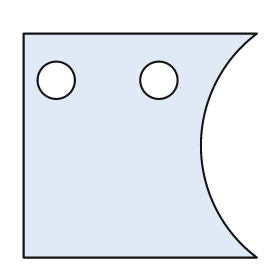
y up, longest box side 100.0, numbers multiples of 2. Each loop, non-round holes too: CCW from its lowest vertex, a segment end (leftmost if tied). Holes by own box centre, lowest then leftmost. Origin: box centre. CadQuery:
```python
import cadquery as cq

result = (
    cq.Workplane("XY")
    .moveTo(-50.0, -48.0)
    .lineTo(50.0, -48.0)
    .threePointArc((26.0, 0.0), (50.0, 48.0))
    .lineTo(-50.0, 48.0)
    .close()
    .moveTo(-36.0, 28.0)
    .circle(8.0)
    .moveTo(8.0, 28.0)
    .circle(8.0)
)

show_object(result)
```